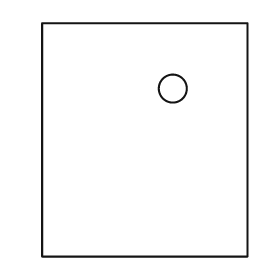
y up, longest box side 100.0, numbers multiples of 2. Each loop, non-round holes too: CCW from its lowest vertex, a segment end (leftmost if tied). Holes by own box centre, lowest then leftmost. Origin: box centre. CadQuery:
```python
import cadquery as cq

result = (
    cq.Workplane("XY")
    .moveTo(-44.0, -50.0)
    .lineTo(44.0, -50.0)
    .lineTo(44.0, 50.0)
    .lineTo(-44.0, 50.0)
    .close()
    .moveTo(12.0, 22.0)
    .circle(6.0)
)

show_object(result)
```